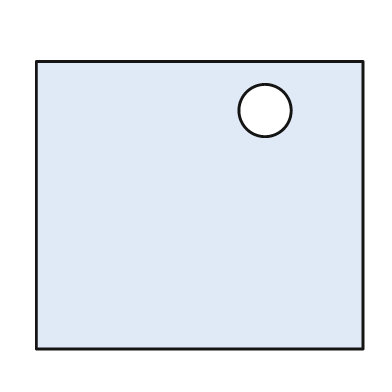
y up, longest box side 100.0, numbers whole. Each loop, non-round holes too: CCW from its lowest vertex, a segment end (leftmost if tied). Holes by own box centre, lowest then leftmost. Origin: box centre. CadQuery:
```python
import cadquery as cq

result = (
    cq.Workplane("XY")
    .moveTo(-50.0, -44.0)
    .lineTo(50.0, -44.0)
    .lineTo(50.0, 44.0)
    .lineTo(-50.0, 44.0)
    .close()
    .moveTo(20.0, 29.0)
    .circle(8.0)
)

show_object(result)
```